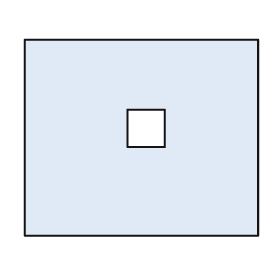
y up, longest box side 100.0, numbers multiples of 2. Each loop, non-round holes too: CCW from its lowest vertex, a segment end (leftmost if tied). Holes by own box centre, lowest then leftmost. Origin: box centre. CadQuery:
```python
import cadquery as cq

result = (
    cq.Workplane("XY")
    .moveTo(-50.0, -42.0)
    .lineTo(50.0, -42.0)
    .lineTo(50.0, 42.0)
    .lineTo(-50.0, 42.0)
    .close()
    .moveTo(-6.0, -4.0)
    .lineTo(10.0, -4.0)
    .lineTo(10.0, 12.0)
    .lineTo(-6.0, 12.0)
    .close()
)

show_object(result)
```